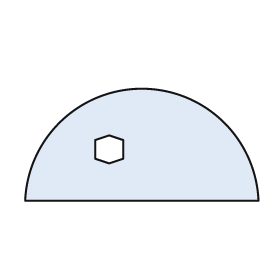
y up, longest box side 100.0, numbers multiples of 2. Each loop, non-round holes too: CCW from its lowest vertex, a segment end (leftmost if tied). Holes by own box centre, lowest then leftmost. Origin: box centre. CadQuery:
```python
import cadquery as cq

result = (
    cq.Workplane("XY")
    .moveTo(-50.0, -24.0)
    .lineTo(50.0, -24.0)
    .threePointArc((0.0, 24.0), (-50.0, -24.0))
    .close()
    .moveTo(-14.0, -8.0)
    .lineTo(-8.0, -6.0)
    .lineTo(-8.0, 2.0)
    .lineTo(-14.0, 4.0)
    .lineTo(-20.0, 2.0)
    .lineTo(-20.0, -6.0)
    .close()
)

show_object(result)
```